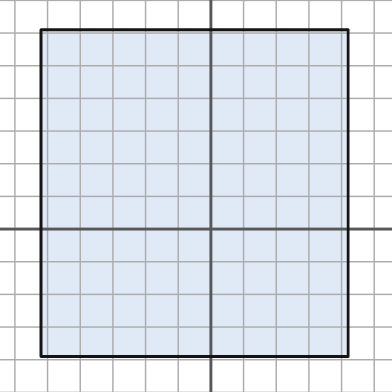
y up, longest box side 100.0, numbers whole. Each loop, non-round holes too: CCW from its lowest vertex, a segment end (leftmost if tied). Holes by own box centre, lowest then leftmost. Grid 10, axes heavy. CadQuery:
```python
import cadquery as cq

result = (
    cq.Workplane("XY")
    .moveTo(-52.0, -39.0)
    .lineTo(42.0, -39.0)
    .lineTo(42.0, 61.0)
    .lineTo(-52.0, 61.0)
    .close()
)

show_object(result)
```